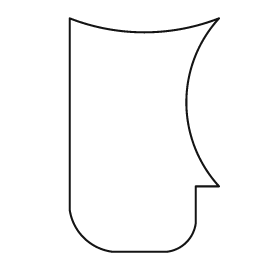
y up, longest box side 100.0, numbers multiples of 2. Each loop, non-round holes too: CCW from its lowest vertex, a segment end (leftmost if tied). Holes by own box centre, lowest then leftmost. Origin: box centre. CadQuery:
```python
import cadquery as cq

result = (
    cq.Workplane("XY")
    .moveTo(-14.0, -50.0)
    .lineTo(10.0, -50.0)
    .threePointArc((18.0, -46.0), (22.0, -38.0))
    .lineTo(22.0, -22.0)
    .lineTo(32.0, -22.0)
    .threePointArc((18.0, 14.0), (32.0, 50.0))
    .threePointArc((0.0, 44.0), (-32.0, 50.0))
    .lineTo(-32.0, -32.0)
    .threePointArc((-26.0, -44.0), (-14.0, -50.0))
    .close()
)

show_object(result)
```